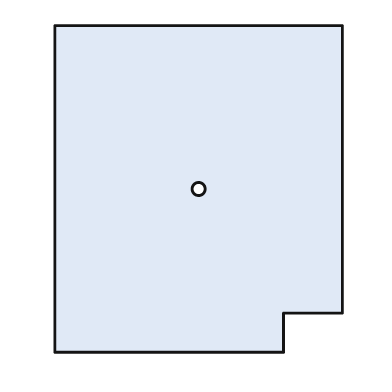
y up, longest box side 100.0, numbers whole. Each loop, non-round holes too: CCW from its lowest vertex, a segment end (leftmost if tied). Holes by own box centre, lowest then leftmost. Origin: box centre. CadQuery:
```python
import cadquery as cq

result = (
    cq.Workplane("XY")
    .moveTo(-44.0, -50.0)
    .lineTo(26.0, -50.0)
    .lineTo(26.0, -38.0)
    .lineTo(44.0, -38.0)
    .lineTo(44.0, 50.0)
    .lineTo(-44.0, 50.0)
    .close()
    .moveTo(0.0, 0.0)
    .circle(2.0)
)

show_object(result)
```